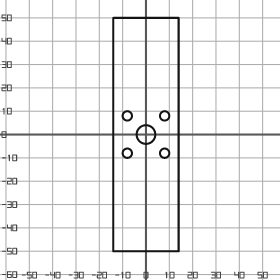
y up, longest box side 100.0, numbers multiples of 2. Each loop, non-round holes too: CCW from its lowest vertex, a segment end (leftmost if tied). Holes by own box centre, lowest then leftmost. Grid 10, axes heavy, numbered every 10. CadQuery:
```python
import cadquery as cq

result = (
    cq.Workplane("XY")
    .moveTo(-14.0, -50.0)
    .lineTo(14.0, -50.0)
    .lineTo(14.0, 50.0)
    .lineTo(-14.0, 50.0)
    .close()
    .moveTo(-8.0, -8.0)
    .circle(2.0)
    .moveTo(8.0, -8.0)
    .circle(2.0)
    .moveTo(0.0, 0.0)
    .circle(4.0)
    .moveTo(-8.0, 8.0)
    .circle(2.0)
    .moveTo(8.0, 8.0)
    .circle(2.0)
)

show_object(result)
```